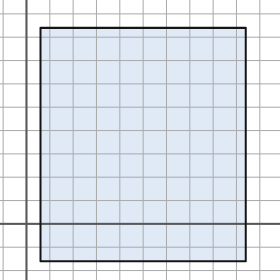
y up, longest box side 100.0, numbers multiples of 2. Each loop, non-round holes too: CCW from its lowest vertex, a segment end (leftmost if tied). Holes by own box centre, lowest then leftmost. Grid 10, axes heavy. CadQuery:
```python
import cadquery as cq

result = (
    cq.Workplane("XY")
    .moveTo(6.0, -16.0)
    .lineTo(94.0, -16.0)
    .lineTo(94.0, 84.0)
    .lineTo(6.0, 84.0)
    .close()
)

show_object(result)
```